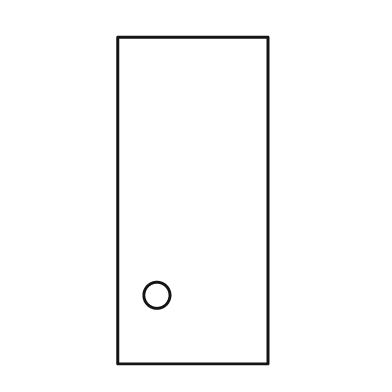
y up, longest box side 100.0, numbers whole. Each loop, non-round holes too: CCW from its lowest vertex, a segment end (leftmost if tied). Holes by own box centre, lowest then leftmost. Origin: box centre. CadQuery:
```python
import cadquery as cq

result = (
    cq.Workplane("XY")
    .moveTo(-23.0, -50.0)
    .lineTo(23.0, -50.0)
    .lineTo(23.0, 50.0)
    .lineTo(-23.0, 50.0)
    .close()
    .moveTo(-11.0, -29.0)
    .circle(4.0)
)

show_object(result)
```